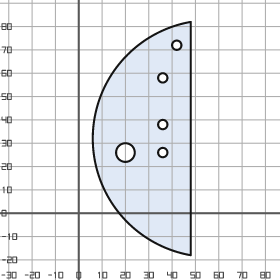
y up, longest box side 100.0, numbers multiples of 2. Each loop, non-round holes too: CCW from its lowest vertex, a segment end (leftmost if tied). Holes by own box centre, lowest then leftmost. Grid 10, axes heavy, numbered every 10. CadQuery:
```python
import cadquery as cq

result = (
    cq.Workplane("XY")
    .moveTo(48.0, -18.0)
    .lineTo(48.0, 82.0)
    .threePointArc((6.0, 32.0), (48.0, -18.0))
    .close()
    .moveTo(20.0, 26.0)
    .circle(4.0)
    .moveTo(36.0, 26.0)
    .circle(2.0)
    .moveTo(36.0, 38.0)
    .circle(2.0)
    .moveTo(36.0, 58.0)
    .circle(2.0)
    .moveTo(42.0, 72.0)
    .circle(2.0)
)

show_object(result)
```